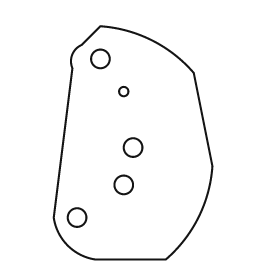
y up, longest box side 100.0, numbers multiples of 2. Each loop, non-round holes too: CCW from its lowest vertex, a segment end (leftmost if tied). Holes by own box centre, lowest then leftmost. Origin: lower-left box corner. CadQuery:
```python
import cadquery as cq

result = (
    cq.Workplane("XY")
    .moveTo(18.0, 0.0)
    .lineTo(48.0, 0.0)
    .threePointArc((62.0, 18.0), (68.0, 40.0))
    .lineTo(60.0, 80.0)
    .threePointArc((42.0, 94.0), (20.0, 100.0))
    .lineTo(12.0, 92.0)
    .threePointArc((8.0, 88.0), (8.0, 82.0))
    .lineTo(0.0, 18.0)
    .threePointArc((6.0, 6.0), (18.0, 0.0))
    .close()
    .moveTo(10.0, 18.0)
    .circle(4.0)
    .moveTo(30.0, 32.0)
    .circle(4.0)
    .moveTo(34.0, 48.0)
    .circle(4.0)
    .moveTo(30.0, 72.0)
    .circle(2.0)
    .moveTo(20.0, 86.0)
    .circle(4.0)
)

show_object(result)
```